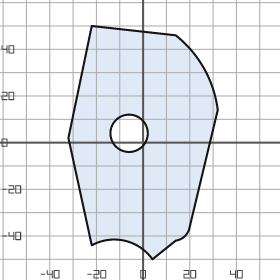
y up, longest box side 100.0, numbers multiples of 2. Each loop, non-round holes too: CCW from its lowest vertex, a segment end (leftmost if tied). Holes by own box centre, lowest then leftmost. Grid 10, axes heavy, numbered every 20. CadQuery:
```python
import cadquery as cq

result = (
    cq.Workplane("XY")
    .moveTo(4.0, -50.0)
    .lineTo(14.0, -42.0)
    .threePointArc((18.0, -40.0), (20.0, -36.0))
    .lineTo(32.0, 14.0)
    .threePointArc((26.0, 32.0), (14.0, 46.0))
    .lineTo(-22.0, 50.0)
    .lineTo(-32.0, 2.0)
    .lineTo(-22.0, -44.0)
    .threePointArc((-8.0, -42.0), (4.0, -50.0))
    .close()
    .moveTo(-6.0, 4.0)
    .circle(8.0)
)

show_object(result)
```